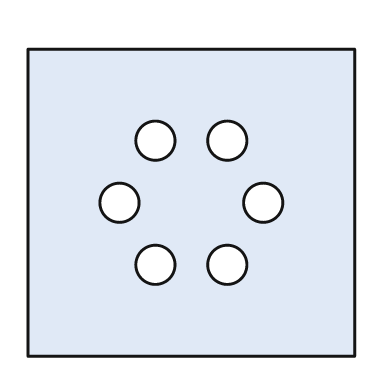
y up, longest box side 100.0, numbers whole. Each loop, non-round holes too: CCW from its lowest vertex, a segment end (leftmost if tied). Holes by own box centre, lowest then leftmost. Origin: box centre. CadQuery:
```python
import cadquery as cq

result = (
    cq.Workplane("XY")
    .moveTo(-50.0, -47.0)
    .lineTo(50.0, -47.0)
    .lineTo(50.0, 47.0)
    .lineTo(-50.0, 47.0)
    .close()
    .moveTo(-11.0, -19.0)
    .circle(6.0)
    .moveTo(11.0, -19.0)
    .circle(6.0)
    .moveTo(-22.0, 0.0)
    .circle(6.0)
    .moveTo(22.0, 0.0)
    .circle(6.0)
    .moveTo(-11.0, 19.0)
    .circle(6.0)
    .moveTo(11.0, 19.0)
    .circle(6.0)
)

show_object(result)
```